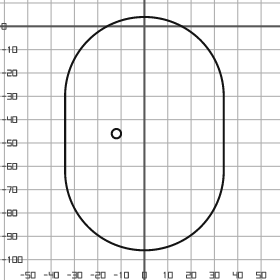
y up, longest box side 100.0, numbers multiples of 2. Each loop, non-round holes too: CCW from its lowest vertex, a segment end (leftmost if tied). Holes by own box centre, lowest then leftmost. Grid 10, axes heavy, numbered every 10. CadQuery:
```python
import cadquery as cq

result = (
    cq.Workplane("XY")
    .moveTo(-34.0, -62.0)
    .threePointArc((0.0, -96.0), (34.0, -62.0))
    .lineTo(34.0, -30.0)
    .threePointArc((0.0, 4.0), (-34.0, -30.0))
    .close()
    .moveTo(-12.0, -46.0)
    .circle(2.0)
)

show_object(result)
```